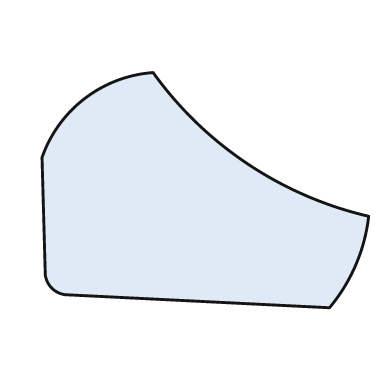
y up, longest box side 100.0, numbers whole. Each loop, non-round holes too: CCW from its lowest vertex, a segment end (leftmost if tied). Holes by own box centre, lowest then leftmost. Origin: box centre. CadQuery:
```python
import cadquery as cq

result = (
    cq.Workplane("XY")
    .moveTo(38.0, -36.0)
    .threePointArc((46.0, -23.0), (50.0, -8.0))
    .threePointArc((13.0, 8.0), (-16.0, 36.0))
    .threePointArc((-37.0, 28.0), (-50.0, 10.0))
    .lineTo(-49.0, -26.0)
    .threePointArc((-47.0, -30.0), (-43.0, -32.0))
    .close()
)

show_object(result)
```